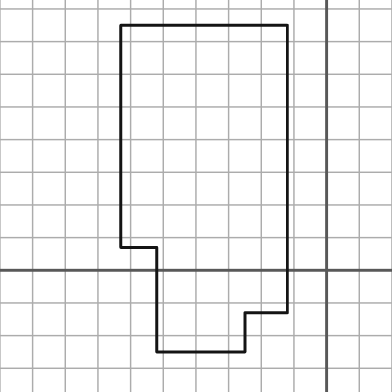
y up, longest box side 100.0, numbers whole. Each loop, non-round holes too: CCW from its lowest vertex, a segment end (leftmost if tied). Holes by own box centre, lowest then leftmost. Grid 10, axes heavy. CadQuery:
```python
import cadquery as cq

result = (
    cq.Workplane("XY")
    .moveTo(-52.0, -25.0)
    .lineTo(-25.0, -25.0)
    .lineTo(-25.0, -13.0)
    .lineTo(-12.0, -13.0)
    .lineTo(-12.0, 75.0)
    .lineTo(-63.0, 75.0)
    .lineTo(-63.0, 7.0)
    .lineTo(-52.0, 7.0)
    .close()
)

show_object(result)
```